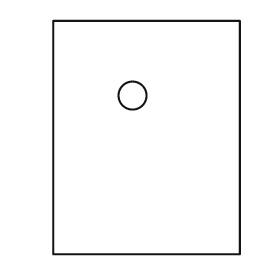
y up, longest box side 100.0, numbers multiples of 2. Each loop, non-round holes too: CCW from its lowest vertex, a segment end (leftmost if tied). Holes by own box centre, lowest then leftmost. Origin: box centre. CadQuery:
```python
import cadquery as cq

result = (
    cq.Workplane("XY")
    .moveTo(-40.0, -50.0)
    .lineTo(40.0, -50.0)
    .lineTo(40.0, 50.0)
    .lineTo(-40.0, 50.0)
    .close()
    .moveTo(-6.0, 18.0)
    .circle(6.0)
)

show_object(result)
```